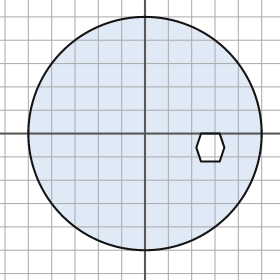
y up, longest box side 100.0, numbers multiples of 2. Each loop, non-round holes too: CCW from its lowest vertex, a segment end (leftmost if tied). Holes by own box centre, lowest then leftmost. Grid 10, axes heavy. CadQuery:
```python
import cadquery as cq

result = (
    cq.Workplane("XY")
    .moveTo(0.0, 0.0)
    .circle(50.0)
    .moveTo(24.0, -12.0)
    .lineTo(32.0, -12.0)
    .lineTo(34.0, -6.0)
    .lineTo(32.0, 0.0)
    .lineTo(24.0, 0.0)
    .lineTo(22.0, -6.0)
    .close()
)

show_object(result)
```